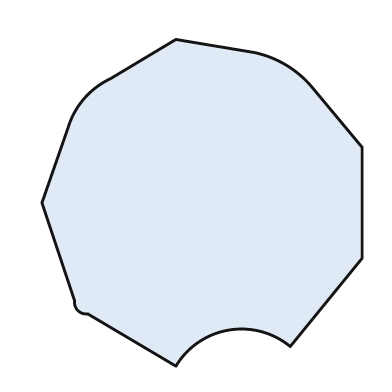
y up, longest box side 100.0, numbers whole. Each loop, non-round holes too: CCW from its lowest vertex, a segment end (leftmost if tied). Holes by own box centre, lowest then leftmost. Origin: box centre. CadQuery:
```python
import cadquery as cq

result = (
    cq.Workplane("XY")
    .moveTo(-8.0, -50.0)
    .threePointArc((8.0, -39.0), (27.0, -44.0))
    .lineTo(49.0, -17.0)
    .lineTo(49.0, 17.0)
    .lineTo(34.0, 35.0)
    .threePointArc((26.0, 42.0), (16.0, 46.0))
    .lineTo(-8.0, 50.0)
    .lineTo(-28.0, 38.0)
    .threePointArc((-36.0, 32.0), (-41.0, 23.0))
    .lineTo(-49.0, 0.0)
    .lineTo(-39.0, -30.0)
    .threePointArc((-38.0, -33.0), (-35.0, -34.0))
    .close()
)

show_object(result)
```